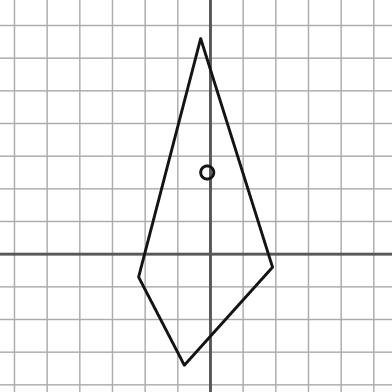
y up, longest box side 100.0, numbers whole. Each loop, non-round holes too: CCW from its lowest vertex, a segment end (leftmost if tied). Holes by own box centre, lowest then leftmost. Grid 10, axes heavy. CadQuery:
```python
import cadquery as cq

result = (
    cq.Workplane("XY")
    .moveTo(-8.0, -34.0)
    .lineTo(19.0, -4.0)
    .lineTo(-3.0, 66.0)
    .lineTo(-22.0, -7.0)
    .close()
    .moveTo(-1.0, 25.0)
    .circle(2.0)
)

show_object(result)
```